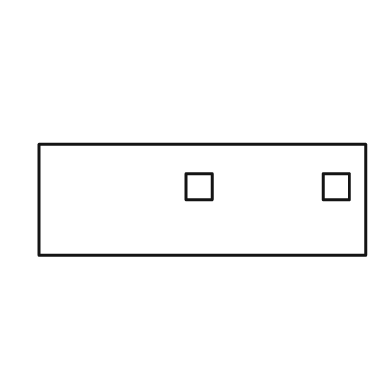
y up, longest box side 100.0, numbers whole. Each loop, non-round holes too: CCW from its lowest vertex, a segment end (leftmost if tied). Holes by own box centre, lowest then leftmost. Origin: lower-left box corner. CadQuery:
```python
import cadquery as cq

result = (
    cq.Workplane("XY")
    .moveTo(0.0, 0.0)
    .lineTo(100.0, 0.0)
    .lineTo(100.0, 34.0)
    .lineTo(0.0, 34.0)
    .close()
    .moveTo(45.0, 17.0)
    .lineTo(53.0, 17.0)
    .lineTo(53.0, 25.0)
    .lineTo(45.0, 25.0)
    .close()
    .moveTo(87.0, 17.0)
    .lineTo(95.0, 17.0)
    .lineTo(95.0, 25.0)
    .lineTo(87.0, 25.0)
    .close()
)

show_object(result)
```